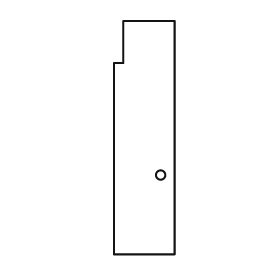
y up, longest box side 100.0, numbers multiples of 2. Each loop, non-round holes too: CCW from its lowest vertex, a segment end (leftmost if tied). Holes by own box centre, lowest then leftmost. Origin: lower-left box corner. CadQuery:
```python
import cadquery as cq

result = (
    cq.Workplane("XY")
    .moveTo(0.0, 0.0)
    .lineTo(26.0, 0.0)
    .lineTo(26.0, 100.0)
    .lineTo(4.0, 100.0)
    .lineTo(4.0, 82.0)
    .lineTo(0.0, 82.0)
    .close()
    .moveTo(20.0, 34.0)
    .circle(2.0)
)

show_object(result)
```